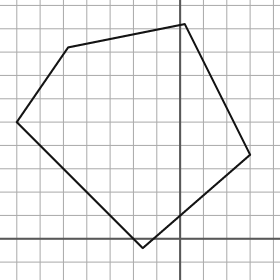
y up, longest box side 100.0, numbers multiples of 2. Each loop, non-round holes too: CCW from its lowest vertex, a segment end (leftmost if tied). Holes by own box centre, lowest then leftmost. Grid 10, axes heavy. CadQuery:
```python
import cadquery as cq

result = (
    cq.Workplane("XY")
    .moveTo(-16.0, -4.0)
    .lineTo(30.0, 36.0)
    .lineTo(2.0, 92.0)
    .lineTo(-48.0, 82.0)
    .lineTo(-70.0, 50.0)
    .close()
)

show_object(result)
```